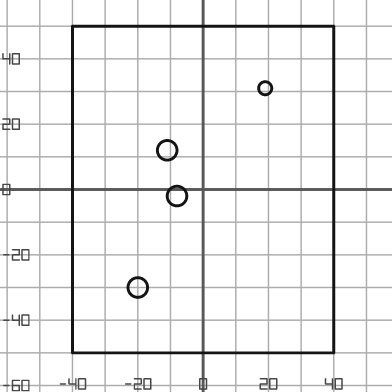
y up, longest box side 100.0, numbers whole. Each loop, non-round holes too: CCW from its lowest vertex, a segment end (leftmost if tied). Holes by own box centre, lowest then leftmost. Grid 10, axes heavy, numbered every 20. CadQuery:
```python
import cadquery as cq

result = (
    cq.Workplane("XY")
    .moveTo(-40.0, -50.0)
    .lineTo(40.0, -50.0)
    .lineTo(40.0, 50.0)
    .lineTo(-40.0, 50.0)
    .close()
    .moveTo(-20.0, -30.0)
    .circle(3.0)
    .moveTo(-8.0, -2.0)
    .circle(3.0)
    .moveTo(-11.0, 12.0)
    .circle(3.0)
    .moveTo(19.0, 31.0)
    .circle(2.0)
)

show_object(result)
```